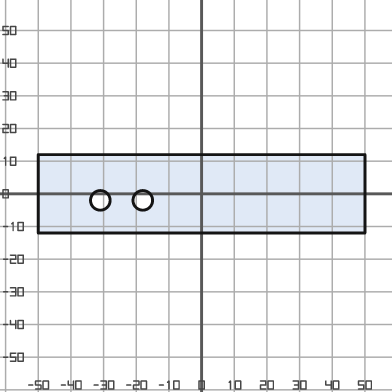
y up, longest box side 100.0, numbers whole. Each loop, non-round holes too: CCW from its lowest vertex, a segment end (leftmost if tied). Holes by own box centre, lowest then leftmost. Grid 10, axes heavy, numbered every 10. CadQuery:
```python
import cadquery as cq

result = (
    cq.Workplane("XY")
    .moveTo(-50.0, -12.0)
    .lineTo(50.0, -12.0)
    .lineTo(50.0, 12.0)
    .lineTo(-50.0, 12.0)
    .close()
    .moveTo(-31.0, -2.0)
    .circle(3.0)
    .moveTo(-18.0, -2.0)
    .circle(3.0)
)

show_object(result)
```